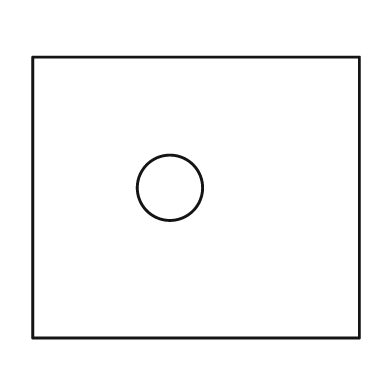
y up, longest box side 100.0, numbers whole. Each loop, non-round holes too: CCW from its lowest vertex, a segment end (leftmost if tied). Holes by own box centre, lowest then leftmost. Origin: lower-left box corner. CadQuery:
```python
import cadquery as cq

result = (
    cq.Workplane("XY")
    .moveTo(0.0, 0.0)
    .lineTo(100.0, 0.0)
    .lineTo(100.0, 86.0)
    .lineTo(0.0, 86.0)
    .close()
    .moveTo(42.0, 46.0)
    .circle(10.0)
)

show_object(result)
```